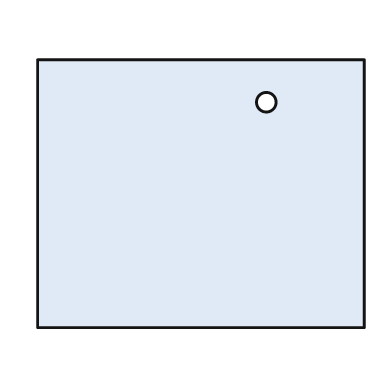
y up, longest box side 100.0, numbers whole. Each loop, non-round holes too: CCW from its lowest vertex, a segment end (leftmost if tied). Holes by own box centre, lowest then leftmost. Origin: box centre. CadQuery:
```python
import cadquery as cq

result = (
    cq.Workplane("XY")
    .moveTo(-50.0, -41.0)
    .lineTo(50.0, -41.0)
    .lineTo(50.0, 41.0)
    .lineTo(-50.0, 41.0)
    .close()
    .moveTo(20.0, 28.0)
    .circle(3.0)
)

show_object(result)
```